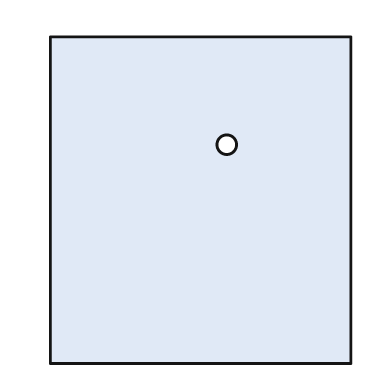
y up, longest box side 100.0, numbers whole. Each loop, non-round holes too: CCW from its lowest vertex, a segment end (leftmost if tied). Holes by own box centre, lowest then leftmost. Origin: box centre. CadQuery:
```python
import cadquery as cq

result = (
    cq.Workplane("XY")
    .moveTo(-46.0, -50.0)
    .lineTo(46.0, -50.0)
    .lineTo(46.0, 50.0)
    .lineTo(-46.0, 50.0)
    .close()
    .moveTo(8.0, 17.0)
    .circle(3.0)
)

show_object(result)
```